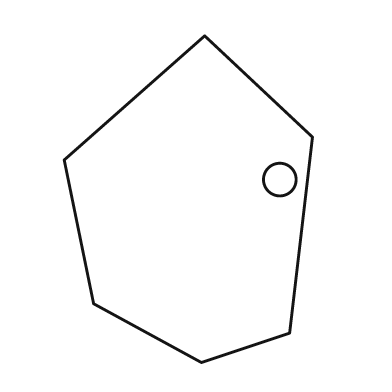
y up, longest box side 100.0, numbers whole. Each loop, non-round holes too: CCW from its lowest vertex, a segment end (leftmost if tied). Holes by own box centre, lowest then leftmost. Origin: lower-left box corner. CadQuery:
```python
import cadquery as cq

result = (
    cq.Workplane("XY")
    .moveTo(42.0, 0.0)
    .lineTo(69.0, 9.0)
    .lineTo(76.0, 69.0)
    .lineTo(43.0, 100.0)
    .lineTo(0.0, 62.0)
    .lineTo(9.0, 18.0)
    .close()
    .moveTo(66.0, 56.0)
    .circle(5.0)
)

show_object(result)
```